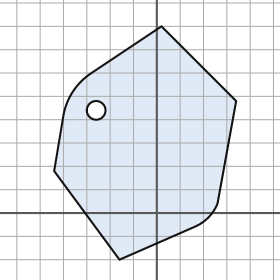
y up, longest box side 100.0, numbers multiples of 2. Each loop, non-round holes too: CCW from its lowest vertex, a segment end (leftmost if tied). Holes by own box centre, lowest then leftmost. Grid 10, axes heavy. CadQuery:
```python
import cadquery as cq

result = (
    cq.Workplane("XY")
    .moveTo(-16.0, -20.0)
    .lineTo(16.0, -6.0)
    .threePointArc((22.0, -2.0), (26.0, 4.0))
    .lineTo(34.0, 48.0)
    .lineTo(2.0, 80.0)
    .lineTo(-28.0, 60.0)
    .threePointArc((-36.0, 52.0), (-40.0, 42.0))
    .lineTo(-44.0, 18.0)
    .close()
    .moveTo(-26.0, 44.0)
    .circle(4.0)
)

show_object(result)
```